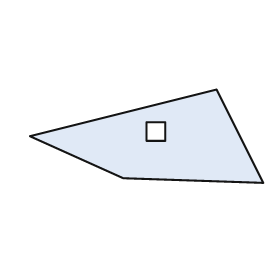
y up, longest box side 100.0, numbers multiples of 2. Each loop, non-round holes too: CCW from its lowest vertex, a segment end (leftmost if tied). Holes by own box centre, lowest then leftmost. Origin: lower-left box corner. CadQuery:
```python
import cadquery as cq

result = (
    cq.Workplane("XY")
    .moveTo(100.0, 0.0)
    .lineTo(80.0, 40.0)
    .lineTo(0.0, 20.0)
    .lineTo(40.0, 2.0)
    .close()
    .moveTo(50.0, 18.0)
    .lineTo(58.0, 18.0)
    .lineTo(58.0, 26.0)
    .lineTo(50.0, 26.0)
    .close()
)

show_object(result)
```